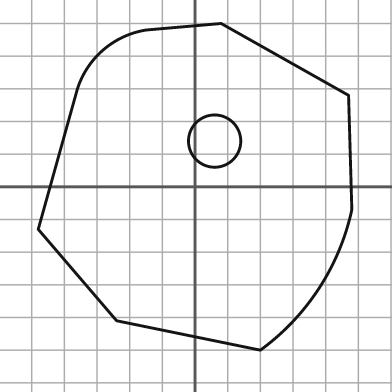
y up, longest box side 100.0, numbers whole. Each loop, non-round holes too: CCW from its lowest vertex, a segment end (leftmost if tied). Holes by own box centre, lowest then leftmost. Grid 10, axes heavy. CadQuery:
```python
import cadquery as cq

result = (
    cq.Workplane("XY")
    .moveTo(20.0, -50.0)
    .threePointArc((38.0, -31.0), (48.0, -7.0))
    .lineTo(47.0, 28.0)
    .lineTo(8.0, 50.0)
    .lineTo(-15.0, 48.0)
    .threePointArc((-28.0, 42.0), (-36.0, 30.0))
    .lineTo(-48.0, -13.0)
    .lineTo(-24.0, -41.0)
    .close()
    .moveTo(6.0, 14.0)
    .circle(8.0)
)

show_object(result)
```